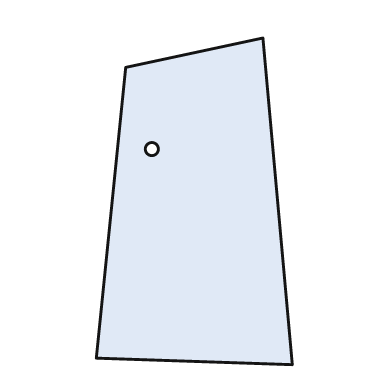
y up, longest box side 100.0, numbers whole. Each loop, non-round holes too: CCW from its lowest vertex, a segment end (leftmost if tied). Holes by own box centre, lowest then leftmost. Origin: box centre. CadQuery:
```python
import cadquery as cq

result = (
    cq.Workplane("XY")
    .moveTo(30.0, -50.0)
    .lineTo(21.0, 50.0)
    .lineTo(-21.0, 41.0)
    .lineTo(-30.0, -48.0)
    .close()
    .moveTo(-13.0, 16.0)
    .circle(2.0)
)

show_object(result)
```